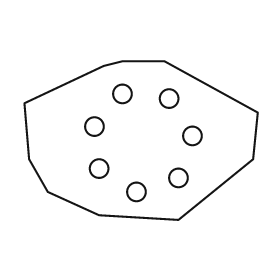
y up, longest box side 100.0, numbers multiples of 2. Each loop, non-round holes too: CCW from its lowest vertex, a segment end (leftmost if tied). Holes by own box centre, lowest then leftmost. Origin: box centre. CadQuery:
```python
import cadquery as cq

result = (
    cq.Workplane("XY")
    .moveTo(16.0, -34.0)
    .lineTo(48.0, -8.0)
    .lineTo(50.0, 12.0)
    .lineTo(10.0, 34.0)
    .lineTo(-8.0, 34.0)
    .lineTo(-16.0, 32.0)
    .lineTo(-50.0, 16.0)
    .lineTo(-48.0, -8.0)
    .lineTo(-40.0, -22.0)
    .lineTo(-18.0, -32.0)
    .close()
    .moveTo(-2.0, -22.0)
    .circle(4.0)
    .moveTo(16.0, -16.0)
    .circle(4.0)
    .moveTo(-18.0, -12.0)
    .circle(4.0)
    .moveTo(22.0, 2.0)
    .circle(4.0)
    .moveTo(-20.0, 6.0)
    .circle(4.0)
    .moveTo(12.0, 18.0)
    .circle(4.0)
    .moveTo(-8.0, 20.0)
    .circle(4.0)
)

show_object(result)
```